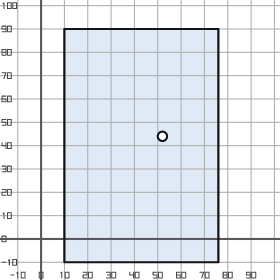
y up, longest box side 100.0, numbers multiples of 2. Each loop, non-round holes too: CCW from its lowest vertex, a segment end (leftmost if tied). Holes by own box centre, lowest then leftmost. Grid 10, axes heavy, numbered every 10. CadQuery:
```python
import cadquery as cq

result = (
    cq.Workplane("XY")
    .moveTo(10.0, -10.0)
    .lineTo(76.0, -10.0)
    .lineTo(76.0, 90.0)
    .lineTo(10.0, 90.0)
    .close()
    .moveTo(52.0, 44.0)
    .circle(2.0)
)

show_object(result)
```